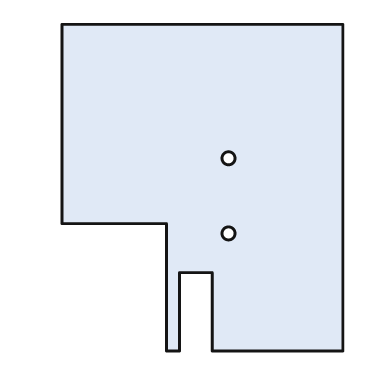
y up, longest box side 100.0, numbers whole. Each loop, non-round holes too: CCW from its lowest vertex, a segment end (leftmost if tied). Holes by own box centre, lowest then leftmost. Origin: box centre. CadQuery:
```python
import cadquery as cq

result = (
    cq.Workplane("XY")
    .moveTo(-11.0, -50.0)
    .lineTo(-7.0, -50.0)
    .lineTo(-7.0, -26.0)
    .lineTo(3.0, -26.0)
    .lineTo(3.0, -50.0)
    .lineTo(43.0, -50.0)
    .lineTo(43.0, 50.0)
    .lineTo(-43.0, 50.0)
    .lineTo(-43.0, -11.0)
    .lineTo(-11.0, -11.0)
    .close()
    .moveTo(8.0, -14.0)
    .circle(2.0)
    .moveTo(8.0, 9.0)
    .circle(2.0)
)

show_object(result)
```